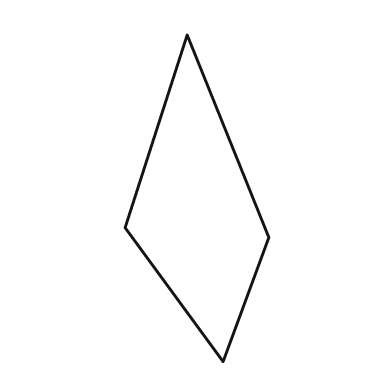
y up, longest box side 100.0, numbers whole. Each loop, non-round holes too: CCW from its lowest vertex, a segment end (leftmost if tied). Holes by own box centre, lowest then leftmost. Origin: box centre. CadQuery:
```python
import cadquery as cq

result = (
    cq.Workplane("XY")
    .moveTo(8.0, -50.0)
    .lineTo(22.0, -12.0)
    .lineTo(-3.0, 50.0)
    .lineTo(-22.0, -9.0)
    .close()
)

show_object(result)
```